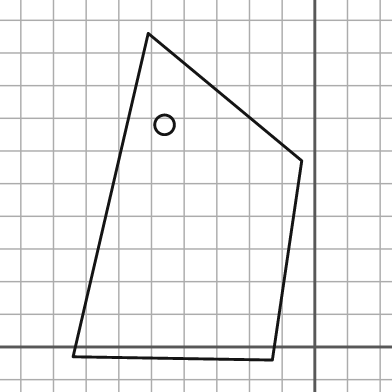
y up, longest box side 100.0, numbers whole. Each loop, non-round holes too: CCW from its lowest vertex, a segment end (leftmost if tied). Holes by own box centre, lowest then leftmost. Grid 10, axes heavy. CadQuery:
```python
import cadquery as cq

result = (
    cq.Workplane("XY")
    .moveTo(-13.0, -4.0)
    .lineTo(-4.0, 57.0)
    .lineTo(-51.0, 96.0)
    .lineTo(-74.0, -3.0)
    .close()
    .moveTo(-46.0, 68.0)
    .circle(3.0)
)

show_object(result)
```